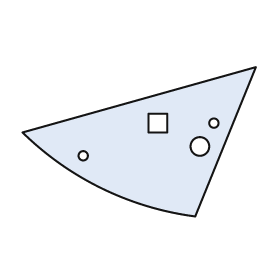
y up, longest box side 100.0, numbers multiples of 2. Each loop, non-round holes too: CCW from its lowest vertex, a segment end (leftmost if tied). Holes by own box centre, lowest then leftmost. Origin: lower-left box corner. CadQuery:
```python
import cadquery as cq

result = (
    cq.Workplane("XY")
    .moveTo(74.0, 0.0)
    .lineTo(100.0, 64.0)
    .lineTo(0.0, 36.0)
    .threePointArc((34.0, 12.0), (74.0, 0.0))
    .close()
    .moveTo(26.0, 26.0)
    .circle(2.0)
    .moveTo(76.0, 30.0)
    .circle(4.0)
    .moveTo(54.0, 36.0)
    .lineTo(62.0, 36.0)
    .lineTo(62.0, 44.0)
    .lineTo(54.0, 44.0)
    .close()
    .moveTo(82.0, 40.0)
    .circle(2.0)
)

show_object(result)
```